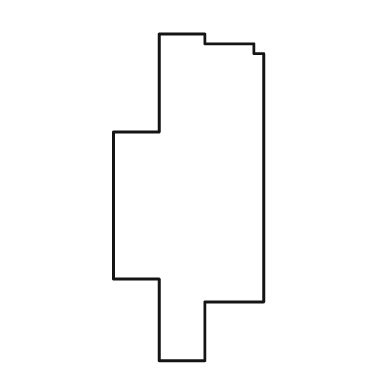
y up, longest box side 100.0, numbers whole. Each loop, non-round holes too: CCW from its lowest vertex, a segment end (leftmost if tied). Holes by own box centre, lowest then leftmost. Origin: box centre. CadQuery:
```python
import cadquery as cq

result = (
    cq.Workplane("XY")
    .moveTo(-9.0, -50.0)
    .lineTo(5.0, -50.0)
    .lineTo(5.0, -32.0)
    .lineTo(23.0, -32.0)
    .lineTo(23.0, 44.0)
    .lineTo(20.0, 44.0)
    .lineTo(20.0, 47.0)
    .lineTo(5.0, 47.0)
    .lineTo(5.0, 50.0)
    .lineTo(-9.0, 50.0)
    .lineTo(-9.0, 20.0)
    .lineTo(-23.0, 20.0)
    .lineTo(-23.0, -25.0)
    .lineTo(-9.0, -25.0)
    .close()
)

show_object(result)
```